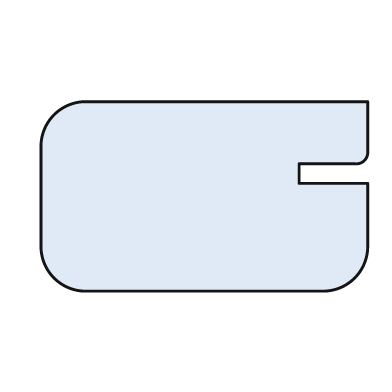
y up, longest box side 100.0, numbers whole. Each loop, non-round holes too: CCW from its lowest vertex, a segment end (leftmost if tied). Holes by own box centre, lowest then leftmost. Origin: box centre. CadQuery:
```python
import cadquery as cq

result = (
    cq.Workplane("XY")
    .moveTo(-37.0, -29.0)
    .lineTo(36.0, -29.0)
    .threePointArc((46.0, -25.0), (50.0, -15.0))
    .lineTo(50.0, 4.0)
    .lineTo(29.0, 4.0)
    .lineTo(29.0, 10.0)
    .lineTo(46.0, 10.0)
    .threePointArc((49.0, 11.0), (50.0, 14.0))
    .lineTo(50.0, 29.0)
    .lineTo(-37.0, 29.0)
    .threePointArc((-46.0, 25.0), (-50.0, 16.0))
    .lineTo(-50.0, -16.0)
    .threePointArc((-46.0, -25.0), (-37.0, -29.0))
    .close()
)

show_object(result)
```